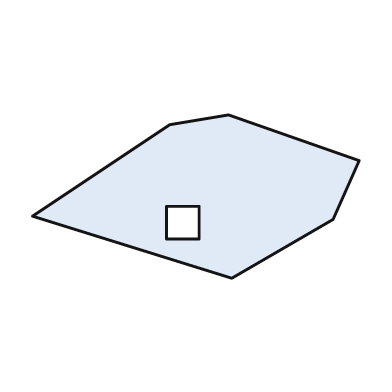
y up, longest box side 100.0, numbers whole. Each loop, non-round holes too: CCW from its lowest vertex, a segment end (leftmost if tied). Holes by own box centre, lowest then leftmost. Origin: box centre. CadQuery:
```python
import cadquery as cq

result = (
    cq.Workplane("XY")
    .moveTo(11.0, -25.0)
    .lineTo(42.0, -7.0)
    .lineTo(50.0, 11.0)
    .lineTo(10.0, 25.0)
    .lineTo(-8.0, 22.0)
    .lineTo(-50.0, -6.0)
    .close()
    .moveTo(-9.0, -13.0)
    .lineTo(1.0, -13.0)
    .lineTo(1.0, -3.0)
    .lineTo(-9.0, -3.0)
    .close()
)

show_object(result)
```